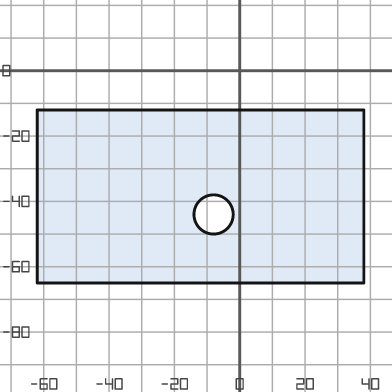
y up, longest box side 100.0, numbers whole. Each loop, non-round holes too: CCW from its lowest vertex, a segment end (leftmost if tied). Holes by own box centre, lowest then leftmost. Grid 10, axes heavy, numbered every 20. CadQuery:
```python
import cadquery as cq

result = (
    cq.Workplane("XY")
    .moveTo(-62.0, -65.0)
    .lineTo(38.0, -65.0)
    .lineTo(38.0, -12.0)
    .lineTo(-62.0, -12.0)
    .close()
    .moveTo(-8.0, -44.0)
    .circle(6.0)
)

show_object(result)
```